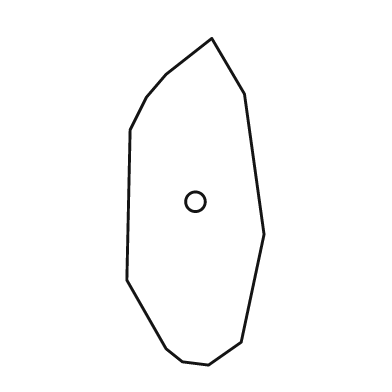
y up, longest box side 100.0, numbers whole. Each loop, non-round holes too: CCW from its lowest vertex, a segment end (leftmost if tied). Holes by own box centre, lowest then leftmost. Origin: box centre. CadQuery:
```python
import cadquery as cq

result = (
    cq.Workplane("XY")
    .moveTo(4.0, -50.0)
    .lineTo(14.0, -43.0)
    .lineTo(21.0, -10.0)
    .lineTo(15.0, 33.0)
    .lineTo(5.0, 50.0)
    .lineTo(-9.0, 39.0)
    .lineTo(-15.0, 32.0)
    .lineTo(-20.0, 22.0)
    .lineTo(-21.0, -24.0)
    .lineTo(-9.0, -45.0)
    .lineTo(-4.0, -49.0)
    .close()
    .moveTo(0.0, 0.0)
    .circle(3.0)
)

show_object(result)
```